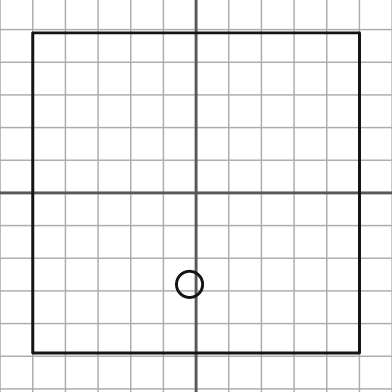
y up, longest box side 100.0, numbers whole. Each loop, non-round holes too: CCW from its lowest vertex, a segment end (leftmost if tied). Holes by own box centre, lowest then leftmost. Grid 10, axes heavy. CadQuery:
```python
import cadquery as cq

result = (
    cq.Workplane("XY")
    .moveTo(-50.0, -49.0)
    .lineTo(50.0, -49.0)
    .lineTo(50.0, 49.0)
    .lineTo(-50.0, 49.0)
    .close()
    .moveTo(-2.0, -28.0)
    .circle(4.0)
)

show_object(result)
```